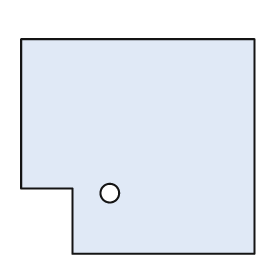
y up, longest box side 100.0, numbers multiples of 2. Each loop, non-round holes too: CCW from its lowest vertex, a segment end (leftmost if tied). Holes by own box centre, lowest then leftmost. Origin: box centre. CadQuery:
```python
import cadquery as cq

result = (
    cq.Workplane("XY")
    .moveTo(-28.0, -46.0)
    .lineTo(50.0, -46.0)
    .lineTo(50.0, 46.0)
    .lineTo(-50.0, 46.0)
    .lineTo(-50.0, -18.0)
    .lineTo(-28.0, -18.0)
    .close()
    .moveTo(-12.0, -20.0)
    .circle(4.0)
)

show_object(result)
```